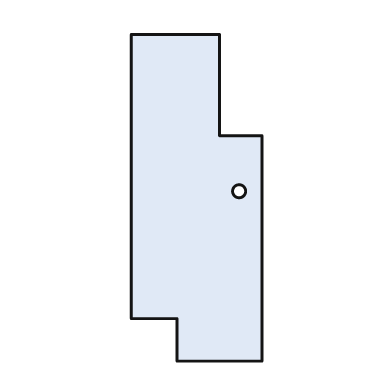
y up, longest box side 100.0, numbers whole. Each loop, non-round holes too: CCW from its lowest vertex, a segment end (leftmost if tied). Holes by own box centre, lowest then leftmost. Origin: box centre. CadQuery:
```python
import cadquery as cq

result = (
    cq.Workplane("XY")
    .moveTo(-6.0, -50.0)
    .lineTo(20.0, -50.0)
    .lineTo(20.0, 19.0)
    .lineTo(7.0, 19.0)
    .lineTo(7.0, 50.0)
    .lineTo(-20.0, 50.0)
    .lineTo(-20.0, -37.0)
    .lineTo(-6.0, -37.0)
    .close()
    .moveTo(13.0, 2.0)
    .circle(2.0)
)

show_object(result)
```